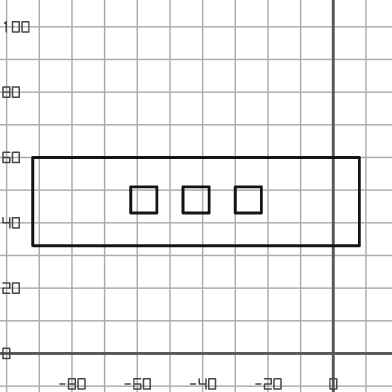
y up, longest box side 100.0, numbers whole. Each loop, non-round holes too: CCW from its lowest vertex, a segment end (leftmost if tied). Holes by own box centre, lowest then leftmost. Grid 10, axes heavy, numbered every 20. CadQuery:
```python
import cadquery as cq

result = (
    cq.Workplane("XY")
    .moveTo(-92.0, 33.0)
    .lineTo(8.0, 33.0)
    .lineTo(8.0, 60.0)
    .lineTo(-92.0, 60.0)
    .close()
    .moveTo(-62.0, 43.0)
    .lineTo(-54.0, 43.0)
    .lineTo(-54.0, 51.0)
    .lineTo(-62.0, 51.0)
    .close()
    .moveTo(-46.0, 43.0)
    .lineTo(-38.0, 43.0)
    .lineTo(-38.0, 51.0)
    .lineTo(-46.0, 51.0)
    .close()
    .moveTo(-30.0, 43.0)
    .lineTo(-22.0, 43.0)
    .lineTo(-22.0, 51.0)
    .lineTo(-30.0, 51.0)
    .close()
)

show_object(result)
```